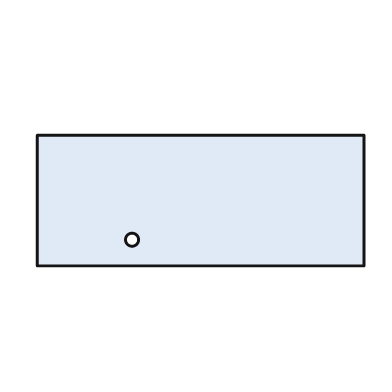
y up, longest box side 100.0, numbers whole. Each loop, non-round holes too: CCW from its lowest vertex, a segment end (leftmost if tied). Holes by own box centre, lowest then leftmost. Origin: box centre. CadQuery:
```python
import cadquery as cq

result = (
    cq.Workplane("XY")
    .moveTo(-50.0, -20.0)
    .lineTo(50.0, -20.0)
    .lineTo(50.0, 20.0)
    .lineTo(-50.0, 20.0)
    .close()
    .moveTo(-21.0, -12.0)
    .circle(2.0)
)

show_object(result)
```